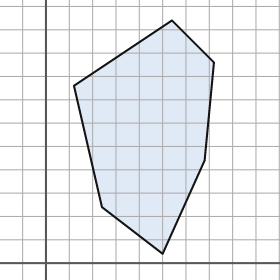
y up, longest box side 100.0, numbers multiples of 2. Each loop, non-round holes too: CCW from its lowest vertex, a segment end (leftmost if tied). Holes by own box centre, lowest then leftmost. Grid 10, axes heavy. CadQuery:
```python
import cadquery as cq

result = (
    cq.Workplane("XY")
    .moveTo(50.0, 4.0)
    .lineTo(68.0, 44.0)
    .lineTo(72.0, 86.0)
    .lineTo(54.0, 104.0)
    .lineTo(12.0, 76.0)
    .lineTo(24.0, 24.0)
    .close()
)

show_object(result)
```